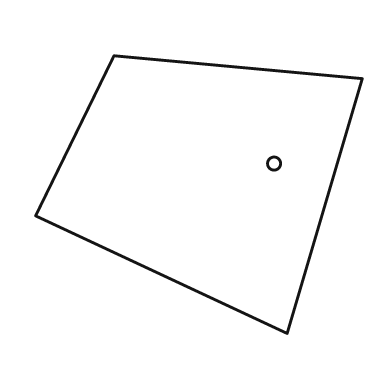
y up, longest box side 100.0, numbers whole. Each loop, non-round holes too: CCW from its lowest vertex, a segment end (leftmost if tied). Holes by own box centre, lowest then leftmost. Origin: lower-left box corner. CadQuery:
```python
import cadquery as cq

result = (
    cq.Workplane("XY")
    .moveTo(77.0, 0.0)
    .lineTo(100.0, 78.0)
    .lineTo(24.0, 85.0)
    .lineTo(0.0, 36.0)
    .close()
    .moveTo(73.0, 52.0)
    .circle(2.0)
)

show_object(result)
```